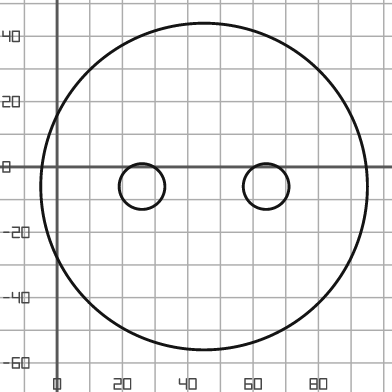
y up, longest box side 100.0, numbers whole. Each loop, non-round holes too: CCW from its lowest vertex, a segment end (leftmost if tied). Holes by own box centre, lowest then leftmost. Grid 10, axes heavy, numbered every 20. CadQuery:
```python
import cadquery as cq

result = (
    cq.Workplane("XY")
    .moveTo(45.0, -6.0)
    .circle(50.0)
    .moveTo(26.0, -6.0)
    .circle(7.0)
    .moveTo(64.0, -6.0)
    .circle(7.0)
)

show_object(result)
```